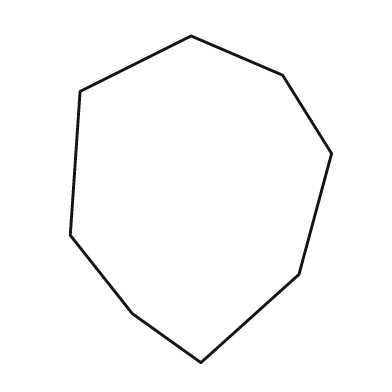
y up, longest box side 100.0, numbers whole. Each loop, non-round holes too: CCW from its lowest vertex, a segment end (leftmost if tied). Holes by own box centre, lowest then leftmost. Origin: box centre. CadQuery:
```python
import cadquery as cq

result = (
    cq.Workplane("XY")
    .moveTo(0.0, -50.0)
    .lineTo(30.0, -23.0)
    .lineTo(40.0, 14.0)
    .lineTo(25.0, 38.0)
    .lineTo(-3.0, 50.0)
    .lineTo(-37.0, 33.0)
    .lineTo(-40.0, -11.0)
    .lineTo(-21.0, -35.0)
    .close()
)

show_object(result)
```